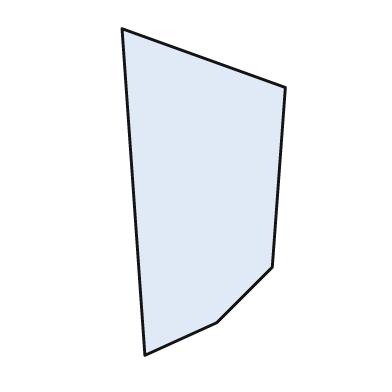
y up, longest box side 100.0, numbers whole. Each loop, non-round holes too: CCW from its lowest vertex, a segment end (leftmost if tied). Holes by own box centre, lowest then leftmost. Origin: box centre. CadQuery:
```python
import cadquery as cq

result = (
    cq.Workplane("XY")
    .moveTo(-18.0, -50.0)
    .lineTo(4.0, -40.0)
    .lineTo(21.0, -23.0)
    .lineTo(25.0, 32.0)
    .lineTo(-25.0, 50.0)
    .close()
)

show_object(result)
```